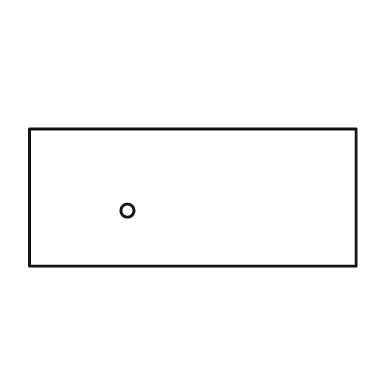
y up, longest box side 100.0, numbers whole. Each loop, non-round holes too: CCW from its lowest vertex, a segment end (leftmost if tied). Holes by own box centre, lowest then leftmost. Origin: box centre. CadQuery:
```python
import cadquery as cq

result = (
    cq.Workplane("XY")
    .moveTo(-50.0, -21.0)
    .lineTo(50.0, -21.0)
    .lineTo(50.0, 21.0)
    .lineTo(-50.0, 21.0)
    .close()
    .moveTo(-20.0, -4.0)
    .circle(2.0)
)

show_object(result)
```